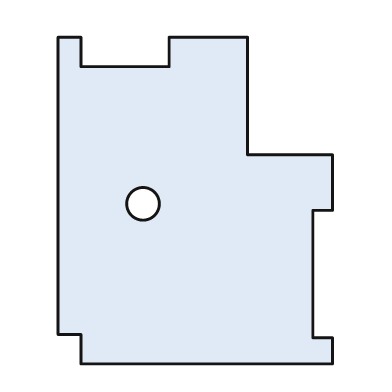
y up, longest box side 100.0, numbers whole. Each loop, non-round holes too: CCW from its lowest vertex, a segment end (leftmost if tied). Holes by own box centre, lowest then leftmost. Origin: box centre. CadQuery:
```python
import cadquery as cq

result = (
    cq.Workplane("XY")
    .moveTo(-35.0, -50.0)
    .lineTo(42.0, -50.0)
    .lineTo(42.0, -42.0)
    .lineTo(36.0, -42.0)
    .lineTo(36.0, -3.0)
    .lineTo(42.0, -3.0)
    .lineTo(42.0, 14.0)
    .lineTo(16.0, 14.0)
    .lineTo(16.0, 50.0)
    .lineTo(-8.0, 50.0)
    .lineTo(-8.0, 41.0)
    .lineTo(-35.0, 41.0)
    .lineTo(-35.0, 50.0)
    .lineTo(-42.0, 50.0)
    .lineTo(-42.0, -41.0)
    .lineTo(-35.0, -41.0)
    .close()
    .moveTo(-16.0, -1.0)
    .circle(5.0)
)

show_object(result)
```